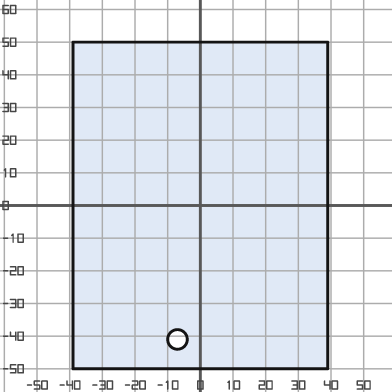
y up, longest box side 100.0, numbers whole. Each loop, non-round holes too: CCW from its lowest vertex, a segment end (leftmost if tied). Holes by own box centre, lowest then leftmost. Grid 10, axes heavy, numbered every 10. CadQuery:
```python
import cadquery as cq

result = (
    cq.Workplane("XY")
    .moveTo(-39.0, -50.0)
    .lineTo(39.0, -50.0)
    .lineTo(39.0, 50.0)
    .lineTo(-39.0, 50.0)
    .close()
    .moveTo(-7.0, -41.0)
    .circle(3.0)
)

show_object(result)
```